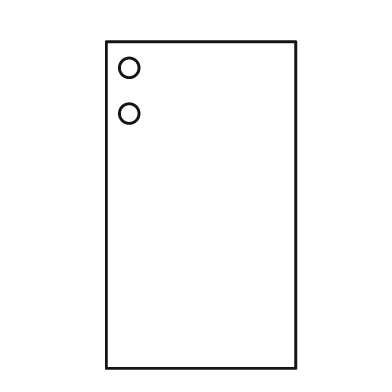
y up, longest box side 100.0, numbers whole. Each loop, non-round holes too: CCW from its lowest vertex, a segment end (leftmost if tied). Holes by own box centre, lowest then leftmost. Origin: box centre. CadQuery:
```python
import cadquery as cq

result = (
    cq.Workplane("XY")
    .moveTo(-29.0, -50.0)
    .lineTo(29.0, -50.0)
    .lineTo(29.0, 50.0)
    .lineTo(-29.0, 50.0)
    .close()
    .moveTo(-22.0, 28.0)
    .circle(3.0)
    .moveTo(-22.0, 42.0)
    .circle(3.0)
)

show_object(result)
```